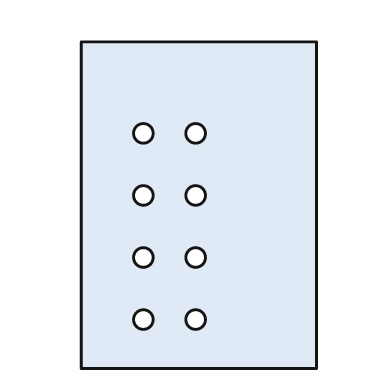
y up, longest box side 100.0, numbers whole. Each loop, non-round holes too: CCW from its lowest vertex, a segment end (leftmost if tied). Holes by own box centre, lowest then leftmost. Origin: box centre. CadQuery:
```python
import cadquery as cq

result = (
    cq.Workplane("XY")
    .moveTo(-36.0, -50.0)
    .lineTo(36.0, -50.0)
    .lineTo(36.0, 50.0)
    .lineTo(-36.0, 50.0)
    .close()
    .moveTo(-17.0, -35.0)
    .circle(3.0)
    .moveTo(-1.0, -35.0)
    .circle(3.0)
    .moveTo(-17.0, -16.0)
    .circle(3.0)
    .moveTo(-1.0, -16.0)
    .circle(3.0)
    .moveTo(-17.0, 3.0)
    .circle(3.0)
    .moveTo(-1.0, 3.0)
    .circle(3.0)
    .moveTo(-17.0, 22.0)
    .circle(3.0)
    .moveTo(-1.0, 22.0)
    .circle(3.0)
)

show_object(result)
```